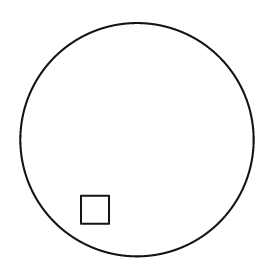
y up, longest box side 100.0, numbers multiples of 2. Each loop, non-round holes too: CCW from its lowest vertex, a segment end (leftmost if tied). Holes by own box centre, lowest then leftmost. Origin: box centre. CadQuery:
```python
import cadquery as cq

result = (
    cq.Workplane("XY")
    .moveTo(0.0, 0.0)
    .circle(50.0)
    .moveTo(-24.0, -36.0)
    .lineTo(-12.0, -36.0)
    .lineTo(-12.0, -24.0)
    .lineTo(-24.0, -24.0)
    .close()
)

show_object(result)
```